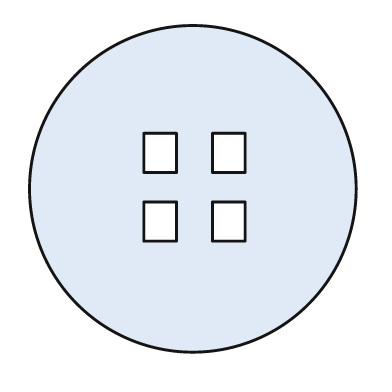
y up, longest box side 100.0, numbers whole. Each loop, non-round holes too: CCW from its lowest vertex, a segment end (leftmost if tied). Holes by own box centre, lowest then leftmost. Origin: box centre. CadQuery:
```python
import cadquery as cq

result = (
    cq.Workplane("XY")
    .moveTo(0.0, 0.0)
    .circle(50.0)
    .moveTo(-15.0, -16.0)
    .lineTo(-5.0, -16.0)
    .lineTo(-5.0, -4.0)
    .lineTo(-15.0, -4.0)
    .close()
    .moveTo(6.0, -16.0)
    .lineTo(16.0, -16.0)
    .lineTo(16.0, -4.0)
    .lineTo(6.0, -4.0)
    .close()
    .moveTo(-15.0, 5.0)
    .lineTo(-5.0, 5.0)
    .lineTo(-5.0, 17.0)
    .lineTo(-15.0, 17.0)
    .close()
    .moveTo(6.0, 5.0)
    .lineTo(16.0, 5.0)
    .lineTo(16.0, 17.0)
    .lineTo(6.0, 17.0)
    .close()
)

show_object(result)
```